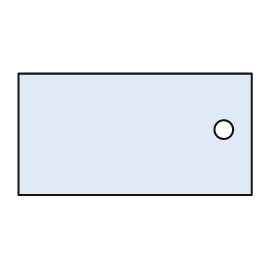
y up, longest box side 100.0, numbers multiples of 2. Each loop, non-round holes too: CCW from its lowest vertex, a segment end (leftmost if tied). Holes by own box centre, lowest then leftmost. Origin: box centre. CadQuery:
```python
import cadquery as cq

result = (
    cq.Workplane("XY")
    .moveTo(-50.0, -26.0)
    .lineTo(50.0, -26.0)
    .lineTo(50.0, 26.0)
    .lineTo(-50.0, 26.0)
    .close()
    .moveTo(38.0, 2.0)
    .circle(4.0)
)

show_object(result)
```